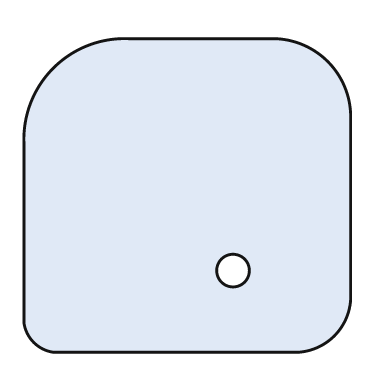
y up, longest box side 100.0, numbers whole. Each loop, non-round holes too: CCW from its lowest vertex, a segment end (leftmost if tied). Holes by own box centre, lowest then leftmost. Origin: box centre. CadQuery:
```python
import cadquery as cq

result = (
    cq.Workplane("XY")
    .moveTo(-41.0, -48.0)
    .lineTo(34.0, -48.0)
    .threePointArc((45.0, -43.0), (50.0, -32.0))
    .lineTo(50.0, 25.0)
    .threePointArc((43.0, 41.0), (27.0, 48.0))
    .lineTo(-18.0, 48.0)
    .threePointArc((-41.0, 39.0), (-50.0, 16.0))
    .lineTo(-50.0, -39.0)
    .threePointArc((-47.0, -45.0), (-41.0, -48.0))
    .close()
    .moveTo(14.0, -23.0)
    .circle(5.0)
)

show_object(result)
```